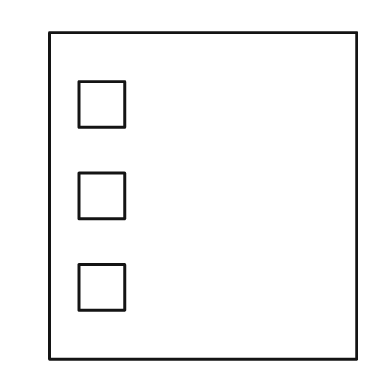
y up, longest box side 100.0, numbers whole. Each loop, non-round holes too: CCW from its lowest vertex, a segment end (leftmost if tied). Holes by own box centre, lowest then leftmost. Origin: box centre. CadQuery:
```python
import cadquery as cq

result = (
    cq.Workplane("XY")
    .moveTo(-47.0, -50.0)
    .lineTo(47.0, -50.0)
    .lineTo(47.0, 50.0)
    .lineTo(-47.0, 50.0)
    .close()
    .moveTo(-38.0, -35.0)
    .lineTo(-24.0, -35.0)
    .lineTo(-24.0, -21.0)
    .lineTo(-38.0, -21.0)
    .close()
    .moveTo(-38.0, -7.0)
    .lineTo(-24.0, -7.0)
    .lineTo(-24.0, 7.0)
    .lineTo(-38.0, 7.0)
    .close()
    .moveTo(-38.0, 21.0)
    .lineTo(-24.0, 21.0)
    .lineTo(-24.0, 35.0)
    .lineTo(-38.0, 35.0)
    .close()
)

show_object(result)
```